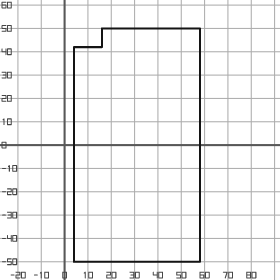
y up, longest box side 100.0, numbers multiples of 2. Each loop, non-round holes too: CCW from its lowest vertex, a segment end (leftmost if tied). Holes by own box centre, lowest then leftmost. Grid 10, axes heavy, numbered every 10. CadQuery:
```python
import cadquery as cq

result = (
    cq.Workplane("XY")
    .moveTo(4.0, -50.0)
    .lineTo(58.0, -50.0)
    .lineTo(58.0, 50.0)
    .lineTo(16.0, 50.0)
    .lineTo(16.0, 42.0)
    .lineTo(4.0, 42.0)
    .close()
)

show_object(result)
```